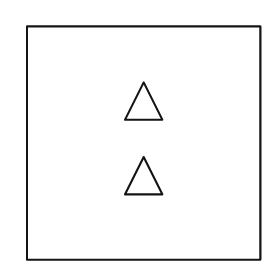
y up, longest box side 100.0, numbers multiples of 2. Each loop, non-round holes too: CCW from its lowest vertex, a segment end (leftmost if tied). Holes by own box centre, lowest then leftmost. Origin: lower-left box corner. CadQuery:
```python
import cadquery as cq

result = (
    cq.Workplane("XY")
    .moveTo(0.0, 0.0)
    .lineTo(100.0, 0.0)
    .lineTo(100.0, 100.0)
    .lineTo(0.0, 100.0)
    .close()
    .moveTo(42.0, 28.0)
    .lineTo(58.0, 28.0)
    .lineTo(50.0, 44.0)
    .close()
    .moveTo(42.0, 60.0)
    .lineTo(58.0, 60.0)
    .lineTo(50.0, 76.0)
    .close()
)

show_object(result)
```